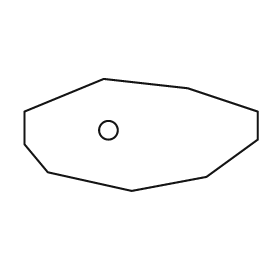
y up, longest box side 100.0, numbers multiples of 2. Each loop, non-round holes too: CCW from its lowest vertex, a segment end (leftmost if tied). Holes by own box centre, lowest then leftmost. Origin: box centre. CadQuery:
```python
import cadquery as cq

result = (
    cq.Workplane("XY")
    .moveTo(-4.0, -24.0)
    .lineTo(28.0, -18.0)
    .lineTo(50.0, -2.0)
    .lineTo(50.0, 10.0)
    .lineTo(20.0, 20.0)
    .lineTo(-16.0, 24.0)
    .lineTo(-50.0, 10.0)
    .lineTo(-50.0, -4.0)
    .lineTo(-40.0, -16.0)
    .close()
    .moveTo(-14.0, 2.0)
    .circle(4.0)
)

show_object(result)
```